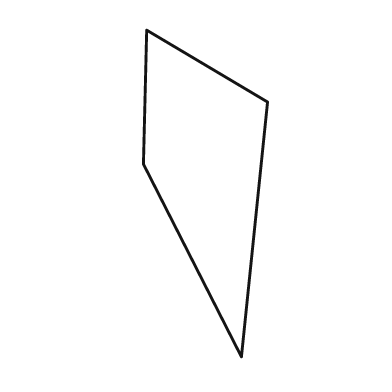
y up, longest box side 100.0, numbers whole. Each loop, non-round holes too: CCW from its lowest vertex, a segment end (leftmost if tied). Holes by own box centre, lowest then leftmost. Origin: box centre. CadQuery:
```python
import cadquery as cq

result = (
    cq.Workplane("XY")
    .moveTo(11.0, -50.0)
    .lineTo(19.0, 28.0)
    .lineTo(-18.0, 50.0)
    .lineTo(-19.0, 9.0)
    .close()
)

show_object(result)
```